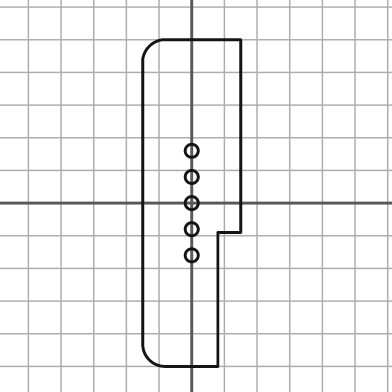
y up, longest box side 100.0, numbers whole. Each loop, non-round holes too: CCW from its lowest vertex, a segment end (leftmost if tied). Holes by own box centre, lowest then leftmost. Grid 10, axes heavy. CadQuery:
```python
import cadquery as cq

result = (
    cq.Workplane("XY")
    .moveTo(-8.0, -50.0)
    .lineTo(8.0, -50.0)
    .lineTo(8.0, -9.0)
    .lineTo(15.0, -9.0)
    .lineTo(15.0, 50.0)
    .lineTo(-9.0, 50.0)
    .threePointArc((-13.0, 48.0), (-15.0, 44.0))
    .lineTo(-15.0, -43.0)
    .threePointArc((-13.0, -48.0), (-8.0, -50.0))
    .close()
    .moveTo(0.0, -16.0)
    .circle(2.0)
    .moveTo(0.0, -8.0)
    .circle(2.0)
    .moveTo(0.0, 0.0)
    .circle(2.0)
    .moveTo(0.0, 8.0)
    .circle(2.0)
    .moveTo(0.0, 16.0)
    .circle(2.0)
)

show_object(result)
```